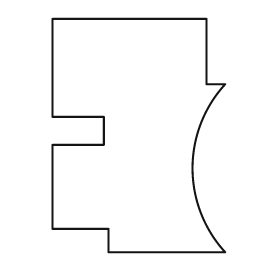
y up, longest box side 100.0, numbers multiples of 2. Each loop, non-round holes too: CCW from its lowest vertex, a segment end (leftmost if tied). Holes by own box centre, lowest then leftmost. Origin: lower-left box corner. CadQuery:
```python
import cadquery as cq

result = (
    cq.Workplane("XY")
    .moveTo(24.0, 0.0)
    .lineTo(74.0, 0.0)
    .threePointArc((60.0, 36.0), (74.0, 72.0))
    .lineTo(66.0, 72.0)
    .lineTo(66.0, 100.0)
    .lineTo(0.0, 100.0)
    .lineTo(0.0, 58.0)
    .lineTo(22.0, 58.0)
    .lineTo(22.0, 46.0)
    .lineTo(0.0, 46.0)
    .lineTo(0.0, 10.0)
    .lineTo(24.0, 10.0)
    .close()
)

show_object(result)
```